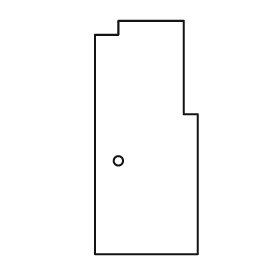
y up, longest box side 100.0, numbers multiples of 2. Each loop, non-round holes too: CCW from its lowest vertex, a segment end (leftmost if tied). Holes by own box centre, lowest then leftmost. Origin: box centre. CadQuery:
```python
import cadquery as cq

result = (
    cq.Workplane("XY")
    .moveTo(-22.0, -50.0)
    .lineTo(22.0, -50.0)
    .lineTo(22.0, 10.0)
    .lineTo(16.0, 10.0)
    .lineTo(16.0, 50.0)
    .lineTo(-12.0, 50.0)
    .lineTo(-12.0, 44.0)
    .lineTo(-22.0, 44.0)
    .close()
    .moveTo(-12.0, -10.0)
    .circle(2.0)
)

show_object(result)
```